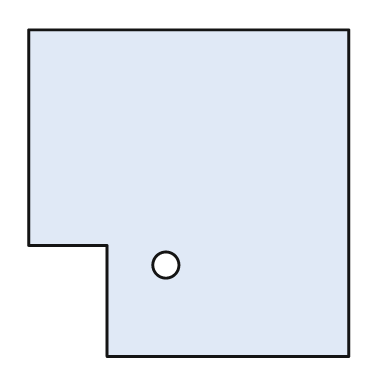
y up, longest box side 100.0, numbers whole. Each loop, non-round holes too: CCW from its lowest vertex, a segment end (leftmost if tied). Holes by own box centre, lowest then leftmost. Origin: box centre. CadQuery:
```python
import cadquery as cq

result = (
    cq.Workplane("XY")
    .moveTo(-25.0, -50.0)
    .lineTo(49.0, -50.0)
    .lineTo(49.0, 50.0)
    .lineTo(-49.0, 50.0)
    .lineTo(-49.0, -16.0)
    .lineTo(-25.0, -16.0)
    .close()
    .moveTo(-7.0, -22.0)
    .circle(4.0)
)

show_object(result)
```